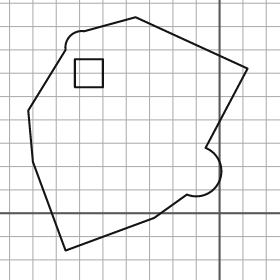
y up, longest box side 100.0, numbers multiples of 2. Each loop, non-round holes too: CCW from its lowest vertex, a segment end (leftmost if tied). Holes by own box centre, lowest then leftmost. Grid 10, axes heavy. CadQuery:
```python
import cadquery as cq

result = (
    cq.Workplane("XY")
    .moveTo(-66.0, -16.0)
    .lineTo(-28.0, -2.0)
    .lineTo(-14.0, 8.0)
    .threePointArc((0.0, 14.0), (-6.0, 28.0))
    .lineTo(12.0, 62.0)
    .lineTo(-36.0, 84.0)
    .lineTo(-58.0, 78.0)
    .threePointArc((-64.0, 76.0), (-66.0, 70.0))
    .lineTo(-82.0, 44.0)
    .lineTo(-80.0, 22.0)
    .close()
    .moveTo(-62.0, 54.0)
    .lineTo(-50.0, 54.0)
    .lineTo(-50.0, 66.0)
    .lineTo(-62.0, 66.0)
    .close()
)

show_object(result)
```